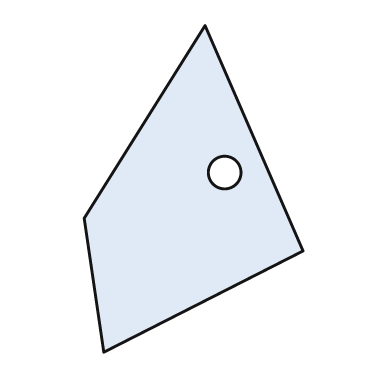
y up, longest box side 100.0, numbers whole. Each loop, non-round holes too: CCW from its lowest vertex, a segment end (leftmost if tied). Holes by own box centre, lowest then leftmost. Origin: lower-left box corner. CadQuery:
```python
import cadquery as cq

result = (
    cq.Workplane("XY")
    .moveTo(6.0, 0.0)
    .lineTo(67.0, 31.0)
    .lineTo(37.0, 100.0)
    .lineTo(0.0, 41.0)
    .close()
    .moveTo(43.0, 55.0)
    .circle(5.0)
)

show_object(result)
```